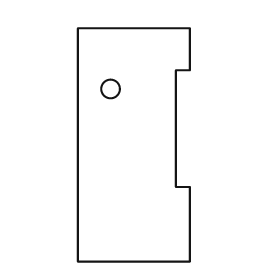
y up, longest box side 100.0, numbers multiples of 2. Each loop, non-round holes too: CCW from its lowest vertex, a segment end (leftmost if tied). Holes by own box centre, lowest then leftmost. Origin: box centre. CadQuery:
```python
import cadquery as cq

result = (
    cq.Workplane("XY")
    .moveTo(-24.0, -50.0)
    .lineTo(24.0, -50.0)
    .lineTo(24.0, -18.0)
    .lineTo(18.0, -18.0)
    .lineTo(18.0, 32.0)
    .lineTo(24.0, 32.0)
    .lineTo(24.0, 50.0)
    .lineTo(-24.0, 50.0)
    .close()
    .moveTo(-10.0, 24.0)
    .circle(4.0)
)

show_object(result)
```